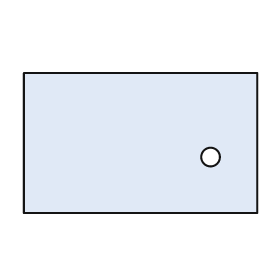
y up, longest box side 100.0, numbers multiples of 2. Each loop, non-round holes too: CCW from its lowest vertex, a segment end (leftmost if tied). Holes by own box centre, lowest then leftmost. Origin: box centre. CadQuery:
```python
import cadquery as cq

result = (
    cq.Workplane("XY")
    .moveTo(-50.0, -30.0)
    .lineTo(50.0, -30.0)
    .lineTo(50.0, 30.0)
    .lineTo(-50.0, 30.0)
    .close()
    .moveTo(30.0, -6.0)
    .circle(4.0)
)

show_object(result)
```